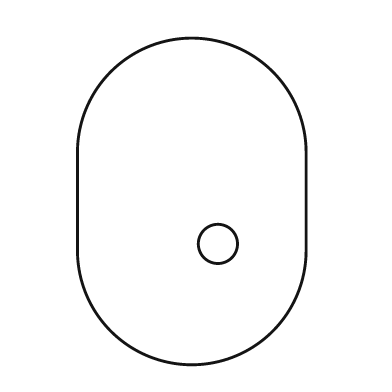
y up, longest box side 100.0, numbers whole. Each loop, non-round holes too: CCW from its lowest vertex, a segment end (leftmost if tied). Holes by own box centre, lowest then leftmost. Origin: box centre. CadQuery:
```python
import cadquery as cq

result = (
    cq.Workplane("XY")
    .moveTo(-35.0, -15.0)
    .threePointArc((0.0, -50.0), (35.0, -15.0))
    .lineTo(35.0, 15.0)
    .threePointArc((0.0, 50.0), (-35.0, 15.0))
    .close()
    .moveTo(8.0, -13.0)
    .circle(6.0)
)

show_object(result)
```